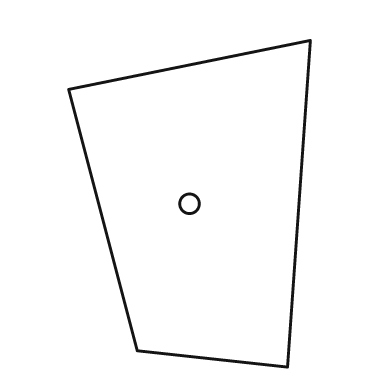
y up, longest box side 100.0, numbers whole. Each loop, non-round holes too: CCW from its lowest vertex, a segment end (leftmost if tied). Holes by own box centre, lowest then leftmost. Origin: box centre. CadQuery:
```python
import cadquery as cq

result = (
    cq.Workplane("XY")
    .moveTo(30.0, -50.0)
    .lineTo(37.0, 50.0)
    .lineTo(-37.0, 35.0)
    .lineTo(-16.0, -45.0)
    .close()
    .moveTo(0.0, 0.0)
    .circle(3.0)
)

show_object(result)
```